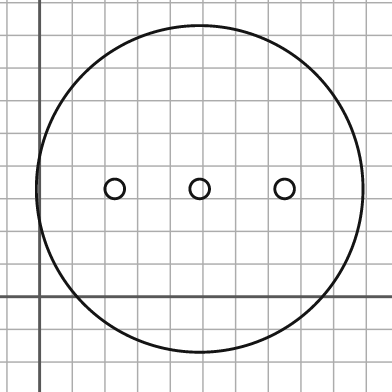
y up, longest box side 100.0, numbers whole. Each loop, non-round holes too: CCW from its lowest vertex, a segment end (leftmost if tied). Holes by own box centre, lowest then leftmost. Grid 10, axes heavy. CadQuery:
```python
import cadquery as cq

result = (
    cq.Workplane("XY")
    .moveTo(49.0, 33.0)
    .circle(50.0)
    .moveTo(23.0, 33.0)
    .circle(3.0)
    .moveTo(49.0, 33.0)
    .circle(3.0)
    .moveTo(75.0, 33.0)
    .circle(3.0)
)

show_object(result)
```